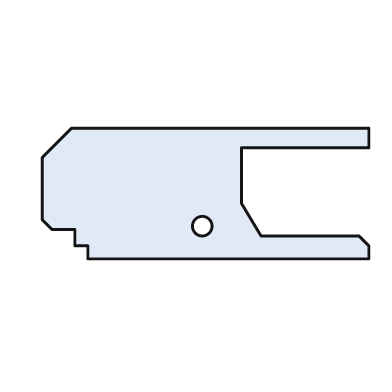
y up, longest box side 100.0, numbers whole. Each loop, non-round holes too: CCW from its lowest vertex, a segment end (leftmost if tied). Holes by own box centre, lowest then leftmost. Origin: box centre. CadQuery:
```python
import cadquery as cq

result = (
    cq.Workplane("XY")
    .moveTo(-36.0, -20.0)
    .lineTo(50.0, -20.0)
    .lineTo(50.0, -16.0)
    .lineTo(47.0, -13.0)
    .lineTo(17.0, -13.0)
    .lineTo(11.0, -3.0)
    .lineTo(11.0, 14.0)
    .lineTo(50.0, 14.0)
    .lineTo(50.0, 20.0)
    .lineTo(-41.0, 20.0)
    .lineTo(-50.0, 11.0)
    .lineTo(-50.0, -8.0)
    .lineTo(-47.0, -11.0)
    .lineTo(-40.0, -11.0)
    .lineTo(-40.0, -16.0)
    .lineTo(-36.0, -16.0)
    .close()
    .moveTo(-1.0, -10.0)
    .circle(3.0)
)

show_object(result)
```